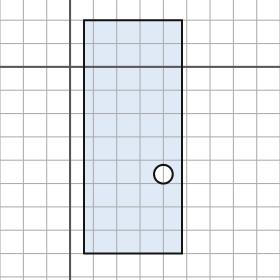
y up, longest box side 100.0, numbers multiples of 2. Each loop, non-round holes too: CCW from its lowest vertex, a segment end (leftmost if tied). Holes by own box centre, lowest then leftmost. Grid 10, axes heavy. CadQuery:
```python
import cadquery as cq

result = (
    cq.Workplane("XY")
    .moveTo(6.0, -80.0)
    .lineTo(48.0, -80.0)
    .lineTo(48.0, 20.0)
    .lineTo(6.0, 20.0)
    .close()
    .moveTo(40.0, -46.0)
    .circle(4.0)
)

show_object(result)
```